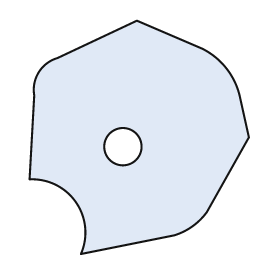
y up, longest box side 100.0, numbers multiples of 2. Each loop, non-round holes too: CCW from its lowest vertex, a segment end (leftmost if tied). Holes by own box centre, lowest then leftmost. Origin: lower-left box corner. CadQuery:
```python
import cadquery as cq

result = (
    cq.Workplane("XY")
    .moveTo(22.0, 0.0)
    .lineTo(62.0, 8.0)
    .threePointArc((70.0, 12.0), (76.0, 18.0))
    .lineTo(94.0, 50.0)
    .lineTo(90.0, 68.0)
    .threePointArc((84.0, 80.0), (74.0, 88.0))
    .lineTo(46.0, 100.0)
    .lineTo(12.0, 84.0)
    .threePointArc((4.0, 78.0), (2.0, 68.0))
    .lineTo(0.0, 32.0)
    .threePointArc((20.0, 22.0), (22.0, 0.0))
    .close()
    .moveTo(40.0, 46.0)
    .circle(8.0)
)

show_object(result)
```